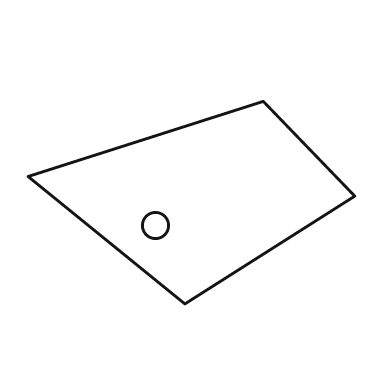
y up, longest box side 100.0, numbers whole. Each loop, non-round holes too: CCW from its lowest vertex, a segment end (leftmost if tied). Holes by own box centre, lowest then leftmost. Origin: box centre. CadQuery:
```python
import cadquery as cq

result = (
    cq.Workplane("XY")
    .moveTo(-2.0, -31.0)
    .lineTo(50.0, 2.0)
    .lineTo(22.0, 31.0)
    .lineTo(-50.0, 8.0)
    .close()
    .moveTo(-11.0, -7.0)
    .circle(4.0)
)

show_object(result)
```